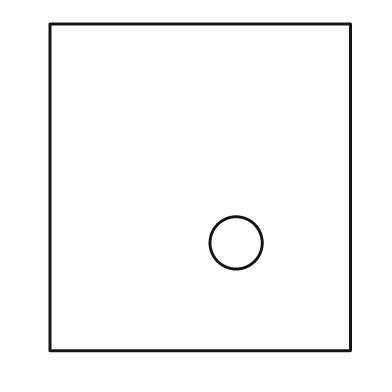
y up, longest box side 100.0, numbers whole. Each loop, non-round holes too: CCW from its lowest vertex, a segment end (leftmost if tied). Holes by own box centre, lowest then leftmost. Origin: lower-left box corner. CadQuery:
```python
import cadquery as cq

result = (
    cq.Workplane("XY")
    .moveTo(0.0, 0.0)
    .lineTo(92.0, 0.0)
    .lineTo(92.0, 100.0)
    .lineTo(0.0, 100.0)
    .close()
    .moveTo(57.0, 33.0)
    .circle(8.0)
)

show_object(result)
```